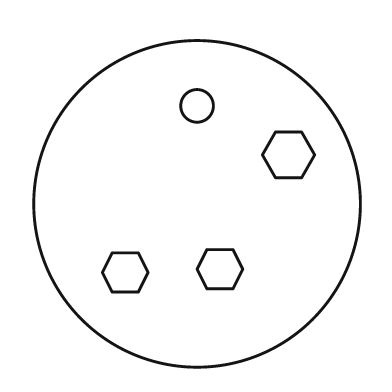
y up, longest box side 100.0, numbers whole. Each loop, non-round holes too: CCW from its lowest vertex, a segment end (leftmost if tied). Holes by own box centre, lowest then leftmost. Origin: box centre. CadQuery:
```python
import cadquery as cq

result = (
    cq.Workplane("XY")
    .moveTo(0.0, 0.0)
    .circle(50.0)
    .moveTo(-26.0, -27.0)
    .lineTo(-18.0, -27.0)
    .lineTo(-15.0, -21.0)
    .lineTo(-18.0, -15.0)
    .lineTo(-26.0, -15.0)
    .lineTo(-29.0, -21.0)
    .close()
    .moveTo(3.0, -26.0)
    .lineTo(11.0, -26.0)
    .lineTo(14.0, -20.0)
    .lineTo(11.0, -14.0)
    .lineTo(3.0, -14.0)
    .lineTo(0.0, -20.0)
    .close()
    .moveTo(24.0, 8.0)
    .lineTo(32.0, 8.0)
    .lineTo(36.0, 15.0)
    .lineTo(32.0, 22.0)
    .lineTo(24.0, 22.0)
    .lineTo(20.0, 15.0)
    .close()
    .moveTo(0.0, 30.0)
    .circle(5.0)
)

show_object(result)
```